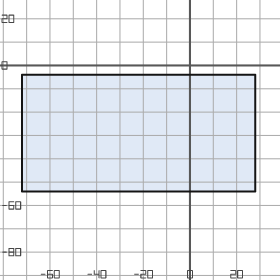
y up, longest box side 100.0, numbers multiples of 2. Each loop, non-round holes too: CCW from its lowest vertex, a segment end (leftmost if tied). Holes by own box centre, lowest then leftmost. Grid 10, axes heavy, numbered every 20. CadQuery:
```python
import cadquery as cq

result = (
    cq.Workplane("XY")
    .moveTo(-72.0, -54.0)
    .lineTo(28.0, -54.0)
    .lineTo(28.0, -4.0)
    .lineTo(-72.0, -4.0)
    .close()
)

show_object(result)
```